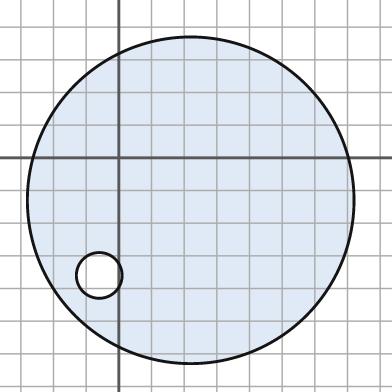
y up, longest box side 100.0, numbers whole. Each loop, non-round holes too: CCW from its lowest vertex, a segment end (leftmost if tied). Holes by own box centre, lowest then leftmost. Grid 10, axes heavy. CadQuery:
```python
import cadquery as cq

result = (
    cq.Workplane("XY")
    .moveTo(22.0, -13.0)
    .circle(50.0)
    .moveTo(-6.0, -36.0)
    .circle(7.0)
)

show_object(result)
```